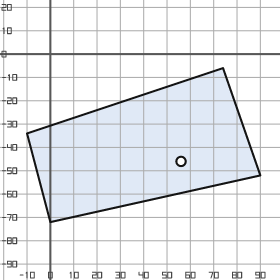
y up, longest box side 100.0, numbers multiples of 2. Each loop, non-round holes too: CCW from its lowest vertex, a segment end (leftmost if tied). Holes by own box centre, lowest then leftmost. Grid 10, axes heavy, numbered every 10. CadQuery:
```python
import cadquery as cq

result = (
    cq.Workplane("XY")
    .moveTo(0.0, -72.0)
    .lineTo(90.0, -52.0)
    .lineTo(74.0, -6.0)
    .lineTo(-10.0, -34.0)
    .close()
    .moveTo(56.0, -46.0)
    .circle(2.0)
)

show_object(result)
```